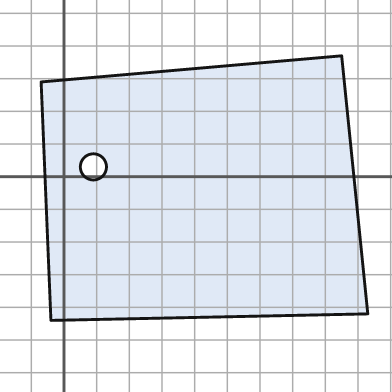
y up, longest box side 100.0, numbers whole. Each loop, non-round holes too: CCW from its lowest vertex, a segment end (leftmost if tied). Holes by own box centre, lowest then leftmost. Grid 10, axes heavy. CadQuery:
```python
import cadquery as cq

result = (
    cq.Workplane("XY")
    .moveTo(-4.0, -44.0)
    .lineTo(93.0, -42.0)
    .lineTo(85.0, 37.0)
    .lineTo(-7.0, 29.0)
    .close()
    .moveTo(9.0, 3.0)
    .circle(4.0)
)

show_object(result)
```